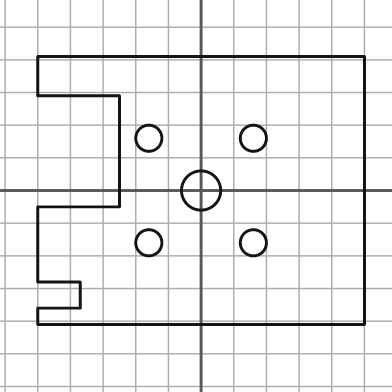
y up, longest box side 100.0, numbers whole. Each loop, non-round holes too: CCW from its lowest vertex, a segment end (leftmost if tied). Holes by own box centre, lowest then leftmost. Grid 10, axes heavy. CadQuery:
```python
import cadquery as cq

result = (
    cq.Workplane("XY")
    .moveTo(-50.0, -41.0)
    .lineTo(50.0, -41.0)
    .lineTo(50.0, 41.0)
    .lineTo(-50.0, 41.0)
    .lineTo(-50.0, 29.0)
    .lineTo(-25.0, 29.0)
    .lineTo(-25.0, -5.0)
    .lineTo(-50.0, -5.0)
    .lineTo(-50.0, -28.0)
    .lineTo(-37.0, -28.0)
    .lineTo(-37.0, -36.0)
    .lineTo(-50.0, -36.0)
    .close()
    .moveTo(-16.0, -16.0)
    .circle(4.0)
    .moveTo(16.0, -16.0)
    .circle(4.0)
    .moveTo(0.0, 0.0)
    .circle(6.0)
    .moveTo(-16.0, 16.0)
    .circle(4.0)
    .moveTo(16.0, 16.0)
    .circle(4.0)
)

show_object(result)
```